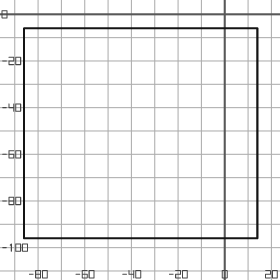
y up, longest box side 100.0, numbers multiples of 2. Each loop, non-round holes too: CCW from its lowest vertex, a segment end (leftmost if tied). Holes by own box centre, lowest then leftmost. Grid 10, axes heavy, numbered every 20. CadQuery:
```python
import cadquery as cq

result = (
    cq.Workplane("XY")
    .moveTo(-86.0, -96.0)
    .lineTo(14.0, -96.0)
    .lineTo(14.0, -6.0)
    .lineTo(-86.0, -6.0)
    .close()
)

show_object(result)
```